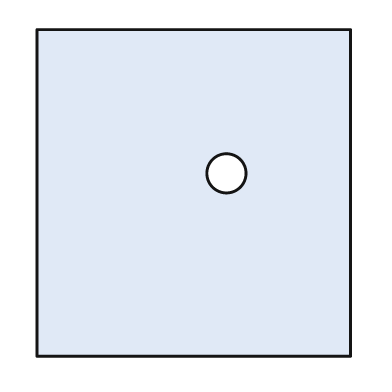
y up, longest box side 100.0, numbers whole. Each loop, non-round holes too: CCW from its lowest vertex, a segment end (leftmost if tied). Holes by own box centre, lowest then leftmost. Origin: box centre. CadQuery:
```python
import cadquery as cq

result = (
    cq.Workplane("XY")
    .moveTo(-48.0, -50.0)
    .lineTo(48.0, -50.0)
    .lineTo(48.0, 50.0)
    .lineTo(-48.0, 50.0)
    .close()
    .moveTo(10.0, 6.0)
    .circle(6.0)
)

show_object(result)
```